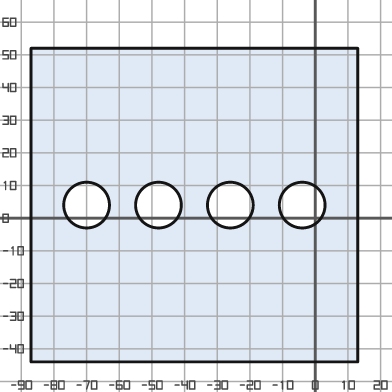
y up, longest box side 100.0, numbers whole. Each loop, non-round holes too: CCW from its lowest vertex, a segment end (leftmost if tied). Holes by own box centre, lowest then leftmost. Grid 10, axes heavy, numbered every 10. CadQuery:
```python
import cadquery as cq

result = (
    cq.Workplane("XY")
    .moveTo(-87.0, -44.0)
    .lineTo(13.0, -44.0)
    .lineTo(13.0, 52.0)
    .lineTo(-87.0, 52.0)
    .close()
    .moveTo(-70.0, 4.0)
    .circle(7.0)
    .moveTo(-48.0, 4.0)
    .circle(7.0)
    .moveTo(-26.0, 4.0)
    .circle(7.0)
    .moveTo(-4.0, 4.0)
    .circle(7.0)
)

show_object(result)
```